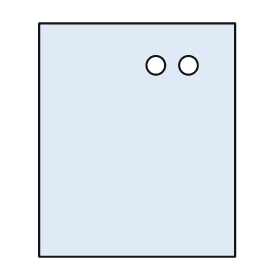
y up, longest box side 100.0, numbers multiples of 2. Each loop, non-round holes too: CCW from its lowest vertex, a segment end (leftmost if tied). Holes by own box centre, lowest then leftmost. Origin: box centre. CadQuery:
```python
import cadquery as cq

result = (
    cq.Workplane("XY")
    .moveTo(-42.0, -50.0)
    .lineTo(42.0, -50.0)
    .lineTo(42.0, 50.0)
    .lineTo(-42.0, 50.0)
    .close()
    .moveTo(8.0, 32.0)
    .circle(4.0)
    .moveTo(22.0, 32.0)
    .circle(4.0)
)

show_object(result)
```